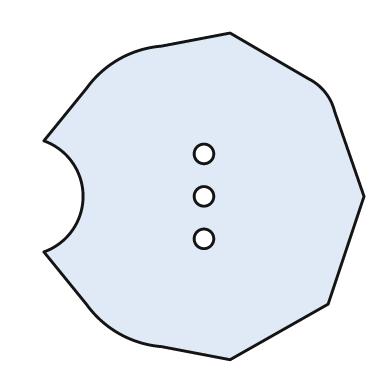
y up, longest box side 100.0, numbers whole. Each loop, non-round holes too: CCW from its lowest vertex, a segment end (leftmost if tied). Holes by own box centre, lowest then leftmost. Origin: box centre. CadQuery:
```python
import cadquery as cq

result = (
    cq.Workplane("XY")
    .moveTo(8.0, -50.0)
    .lineTo(38.0, -33.0)
    .lineTo(49.0, 0.0)
    .lineTo(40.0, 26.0)
    .threePointArc((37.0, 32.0), (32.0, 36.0))
    .lineTo(8.0, 50.0)
    .lineTo(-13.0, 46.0)
    .threePointArc((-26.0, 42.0), (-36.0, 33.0))
    .lineTo(-49.0, 17.0)
    .threePointArc((-37.0, 0.0), (-49.0, -17.0))
    .lineTo(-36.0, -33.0)
    .threePointArc((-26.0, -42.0), (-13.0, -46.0))
    .close()
    .moveTo(0.0, -13.0)
    .circle(3.0)
    .moveTo(0.0, 0.0)
    .circle(3.0)
    .moveTo(0.0, 13.0)
    .circle(3.0)
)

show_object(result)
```